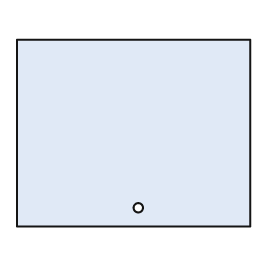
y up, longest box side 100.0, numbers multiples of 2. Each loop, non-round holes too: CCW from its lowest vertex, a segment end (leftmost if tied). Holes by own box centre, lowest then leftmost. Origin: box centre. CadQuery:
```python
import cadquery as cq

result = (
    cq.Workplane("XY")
    .moveTo(-50.0, -40.0)
    .lineTo(50.0, -40.0)
    .lineTo(50.0, 40.0)
    .lineTo(-50.0, 40.0)
    .close()
    .moveTo(2.0, -32.0)
    .circle(2.0)
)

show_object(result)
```